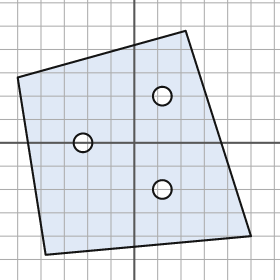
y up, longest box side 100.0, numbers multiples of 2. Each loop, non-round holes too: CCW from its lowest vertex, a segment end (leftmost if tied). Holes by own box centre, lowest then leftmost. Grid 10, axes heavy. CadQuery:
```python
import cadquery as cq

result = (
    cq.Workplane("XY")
    .moveTo(-38.0, -48.0)
    .lineTo(50.0, -40.0)
    .lineTo(22.0, 48.0)
    .lineTo(-50.0, 28.0)
    .close()
    .moveTo(12.0, -20.0)
    .circle(4.0)
    .moveTo(-22.0, 0.0)
    .circle(4.0)
    .moveTo(12.0, 20.0)
    .circle(4.0)
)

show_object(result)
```